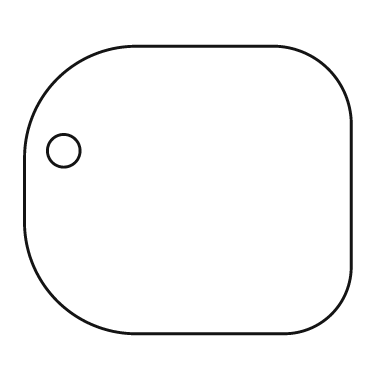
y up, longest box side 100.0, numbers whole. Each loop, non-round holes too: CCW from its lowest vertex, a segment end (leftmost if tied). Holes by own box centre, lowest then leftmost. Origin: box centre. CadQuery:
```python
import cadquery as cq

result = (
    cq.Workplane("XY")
    .moveTo(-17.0, -44.0)
    .lineTo(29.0, -44.0)
    .threePointArc((44.0, -38.0), (50.0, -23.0))
    .lineTo(50.0, 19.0)
    .threePointArc((43.0, 37.0), (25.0, 44.0))
    .lineTo(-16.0, 44.0)
    .threePointArc((-40.0, 34.0), (-50.0, 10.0))
    .lineTo(-50.0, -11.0)
    .threePointArc((-40.0, -34.0), (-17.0, -44.0))
    .close()
    .moveTo(-38.0, 12.0)
    .circle(5.0)
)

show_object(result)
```